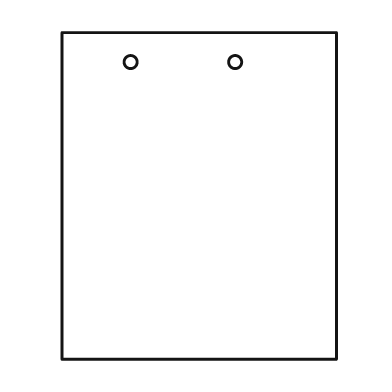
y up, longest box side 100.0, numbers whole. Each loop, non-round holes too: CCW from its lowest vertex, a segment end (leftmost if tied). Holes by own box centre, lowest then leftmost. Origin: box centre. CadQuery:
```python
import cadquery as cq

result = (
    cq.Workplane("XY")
    .moveTo(-42.0, -50.0)
    .lineTo(42.0, -50.0)
    .lineTo(42.0, 50.0)
    .lineTo(-42.0, 50.0)
    .close()
    .moveTo(-21.0, 41.0)
    .circle(2.0)
    .moveTo(11.0, 41.0)
    .circle(2.0)
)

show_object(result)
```